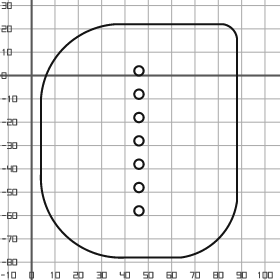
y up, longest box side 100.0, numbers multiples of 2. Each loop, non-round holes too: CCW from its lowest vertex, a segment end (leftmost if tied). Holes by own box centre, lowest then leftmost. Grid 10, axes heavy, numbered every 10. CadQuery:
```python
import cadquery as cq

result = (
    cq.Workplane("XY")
    .moveTo(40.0, -78.0)
    .lineTo(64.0, -78.0)
    .threePointArc((80.0, -70.0), (88.0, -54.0))
    .lineTo(88.0, 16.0)
    .threePointArc((86.0, 20.0), (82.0, 22.0))
    .lineTo(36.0, 22.0)
    .threePointArc((14.0, 12.0), (4.0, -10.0))
    .lineTo(4.0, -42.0)
    .threePointArc((14.0, -68.0), (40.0, -78.0))
    .close()
    .moveTo(46.0, -58.0)
    .circle(2.0)
    .moveTo(46.0, -48.0)
    .circle(2.0)
    .moveTo(46.0, -38.0)
    .circle(2.0)
    .moveTo(46.0, -28.0)
    .circle(2.0)
    .moveTo(46.0, -18.0)
    .circle(2.0)
    .moveTo(46.0, -8.0)
    .circle(2.0)
    .moveTo(46.0, 2.0)
    .circle(2.0)
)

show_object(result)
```